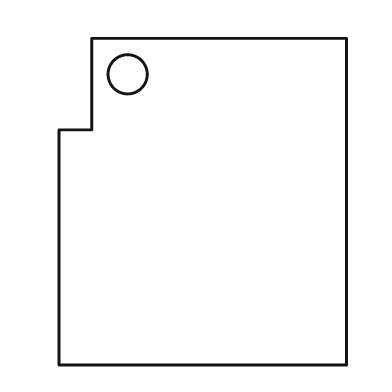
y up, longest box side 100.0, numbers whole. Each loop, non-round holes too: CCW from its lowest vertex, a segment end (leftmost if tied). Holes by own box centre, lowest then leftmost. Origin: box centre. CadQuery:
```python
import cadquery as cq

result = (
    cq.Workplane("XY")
    .moveTo(-44.0, -50.0)
    .lineTo(44.0, -50.0)
    .lineTo(44.0, 50.0)
    .lineTo(-34.0, 50.0)
    .lineTo(-34.0, 22.0)
    .lineTo(-44.0, 22.0)
    .close()
    .moveTo(-23.0, 39.0)
    .circle(6.0)
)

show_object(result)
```